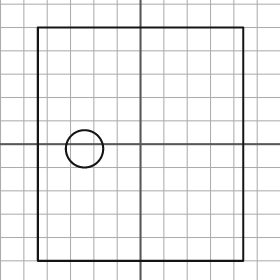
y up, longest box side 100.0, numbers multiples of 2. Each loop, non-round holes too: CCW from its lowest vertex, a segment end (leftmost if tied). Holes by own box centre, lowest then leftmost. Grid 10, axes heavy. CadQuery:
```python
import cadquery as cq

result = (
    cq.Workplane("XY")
    .moveTo(-44.0, -50.0)
    .lineTo(44.0, -50.0)
    .lineTo(44.0, 50.0)
    .lineTo(-44.0, 50.0)
    .close()
    .moveTo(-24.0, -2.0)
    .circle(8.0)
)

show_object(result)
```